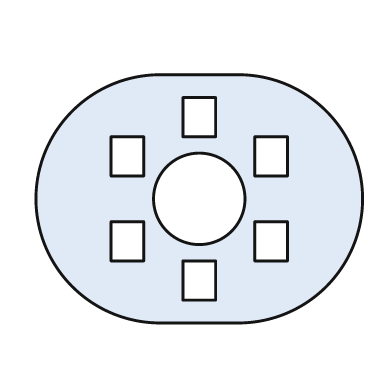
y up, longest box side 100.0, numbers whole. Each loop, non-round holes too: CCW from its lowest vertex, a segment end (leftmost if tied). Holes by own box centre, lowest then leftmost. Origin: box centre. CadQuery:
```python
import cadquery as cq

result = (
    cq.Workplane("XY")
    .moveTo(-12.0, -38.0)
    .lineTo(12.0, -38.0)
    .threePointArc((50.0, 0.0), (12.0, 38.0))
    .lineTo(-12.0, 38.0)
    .threePointArc((-50.0, 0.0), (-12.0, -38.0))
    .close()
    .moveTo(-5.0, -31.0)
    .lineTo(5.0, -31.0)
    .lineTo(5.0, -19.0)
    .lineTo(-5.0, -19.0)
    .close()
    .moveTo(-27.0, -19.0)
    .lineTo(-17.0, -19.0)
    .lineTo(-17.0, -7.0)
    .lineTo(-27.0, -7.0)
    .close()
    .moveTo(17.0, -19.0)
    .lineTo(27.0, -19.0)
    .lineTo(27.0, -7.0)
    .lineTo(17.0, -7.0)
    .close()
    .moveTo(0.0, 0.0)
    .circle(14.0)
    .moveTo(-27.0, 7.0)
    .lineTo(-17.0, 7.0)
    .lineTo(-17.0, 19.0)
    .lineTo(-27.0, 19.0)
    .close()
    .moveTo(17.0, 7.0)
    .lineTo(27.0, 7.0)
    .lineTo(27.0, 19.0)
    .lineTo(17.0, 19.0)
    .close()
    .moveTo(-5.0, 19.0)
    .lineTo(5.0, 19.0)
    .lineTo(5.0, 31.0)
    .lineTo(-5.0, 31.0)
    .close()
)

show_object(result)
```